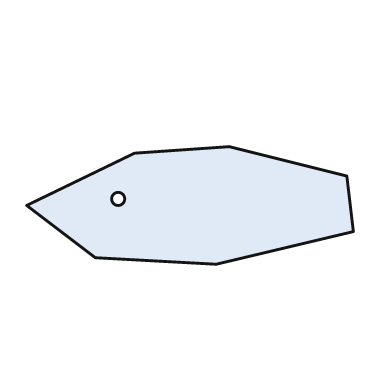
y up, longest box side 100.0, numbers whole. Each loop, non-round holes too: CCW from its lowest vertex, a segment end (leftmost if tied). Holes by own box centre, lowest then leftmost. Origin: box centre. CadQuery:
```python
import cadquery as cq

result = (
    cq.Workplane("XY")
    .moveTo(8.0, -18.0)
    .lineTo(50.0, -8.0)
    .lineTo(48.0, 9.0)
    .lineTo(12.0, 18.0)
    .lineTo(-17.0, 16.0)
    .lineTo(-50.0, 0.0)
    .lineTo(-29.0, -16.0)
    .close()
    .moveTo(-22.0, 2.0)
    .circle(2.0)
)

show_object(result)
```